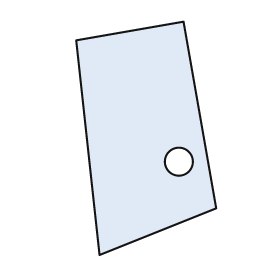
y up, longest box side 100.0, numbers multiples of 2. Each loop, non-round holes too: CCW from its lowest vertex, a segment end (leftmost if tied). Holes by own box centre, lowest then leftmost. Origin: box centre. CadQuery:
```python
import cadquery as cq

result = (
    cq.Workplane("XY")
    .moveTo(-20.0, -50.0)
    .lineTo(30.0, -30.0)
    .lineTo(16.0, 50.0)
    .lineTo(-30.0, 42.0)
    .close()
    .moveTo(14.0, -10.0)
    .circle(6.0)
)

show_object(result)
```